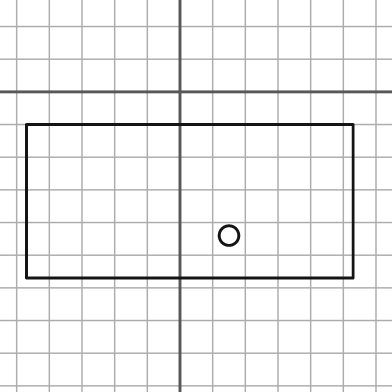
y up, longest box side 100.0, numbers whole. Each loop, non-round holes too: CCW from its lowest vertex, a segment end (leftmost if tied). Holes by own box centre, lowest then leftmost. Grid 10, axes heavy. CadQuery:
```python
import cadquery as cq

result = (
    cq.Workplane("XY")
    .moveTo(-47.0, -57.0)
    .lineTo(53.0, -57.0)
    .lineTo(53.0, -10.0)
    .lineTo(-47.0, -10.0)
    .close()
    .moveTo(15.0, -44.0)
    .circle(3.0)
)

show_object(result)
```